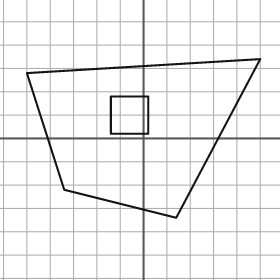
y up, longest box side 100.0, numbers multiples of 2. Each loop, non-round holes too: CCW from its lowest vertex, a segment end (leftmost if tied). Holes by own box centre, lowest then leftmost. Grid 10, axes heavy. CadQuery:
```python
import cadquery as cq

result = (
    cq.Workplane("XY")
    .moveTo(14.0, -34.0)
    .lineTo(50.0, 34.0)
    .lineTo(-50.0, 28.0)
    .lineTo(-34.0, -22.0)
    .close()
    .moveTo(-14.0, 2.0)
    .lineTo(2.0, 2.0)
    .lineTo(2.0, 18.0)
    .lineTo(-14.0, 18.0)
    .close()
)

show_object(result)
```